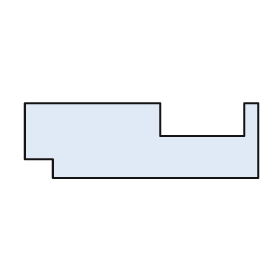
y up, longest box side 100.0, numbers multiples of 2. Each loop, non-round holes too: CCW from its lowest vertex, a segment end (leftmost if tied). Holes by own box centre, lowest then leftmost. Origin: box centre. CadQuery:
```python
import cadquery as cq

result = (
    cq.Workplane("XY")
    .moveTo(-38.0, -16.0)
    .lineTo(50.0, -16.0)
    .lineTo(50.0, 16.0)
    .lineTo(44.0, 16.0)
    .lineTo(44.0, 2.0)
    .lineTo(8.0, 2.0)
    .lineTo(8.0, 16.0)
    .lineTo(-50.0, 16.0)
    .lineTo(-50.0, -8.0)
    .lineTo(-38.0, -8.0)
    .close()
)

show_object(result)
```